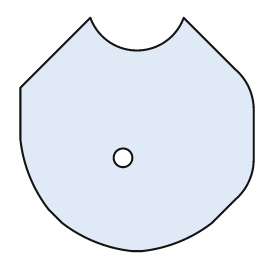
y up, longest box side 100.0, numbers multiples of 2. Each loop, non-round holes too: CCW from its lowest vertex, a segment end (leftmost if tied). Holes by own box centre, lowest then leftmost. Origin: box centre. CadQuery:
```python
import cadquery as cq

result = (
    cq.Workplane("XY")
    .moveTo(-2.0, -50.0)
    .lineTo(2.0, -50.0)
    .threePointArc((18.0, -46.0), (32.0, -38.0))
    .lineTo(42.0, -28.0)
    .threePointArc((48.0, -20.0), (50.0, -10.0))
    .lineTo(50.0, 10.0)
    .threePointArc((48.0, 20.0), (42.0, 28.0))
    .lineTo(20.0, 50.0)
    .threePointArc((0.0, 36.0), (-20.0, 50.0))
    .lineTo(-50.0, 20.0)
    .lineTo(-50.0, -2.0)
    .threePointArc((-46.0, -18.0), (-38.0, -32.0))
    .lineTo(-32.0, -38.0)
    .threePointArc((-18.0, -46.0), (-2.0, -50.0))
    .close()
    .moveTo(-6.0, -10.0)
    .circle(4.0)
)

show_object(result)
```